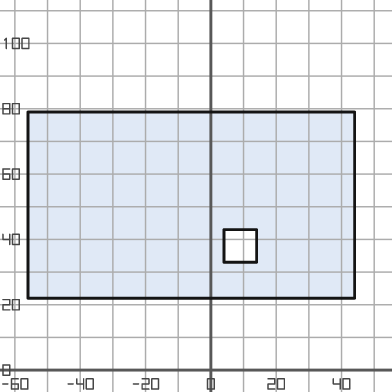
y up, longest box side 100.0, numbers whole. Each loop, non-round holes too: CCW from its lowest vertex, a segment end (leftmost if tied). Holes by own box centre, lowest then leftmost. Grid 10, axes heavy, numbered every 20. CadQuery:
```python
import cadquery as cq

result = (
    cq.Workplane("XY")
    .moveTo(-56.0, 22.0)
    .lineTo(44.0, 22.0)
    .lineTo(44.0, 79.0)
    .lineTo(-56.0, 79.0)
    .close()
    .moveTo(4.0, 33.0)
    .lineTo(14.0, 33.0)
    .lineTo(14.0, 43.0)
    .lineTo(4.0, 43.0)
    .close()
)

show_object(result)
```